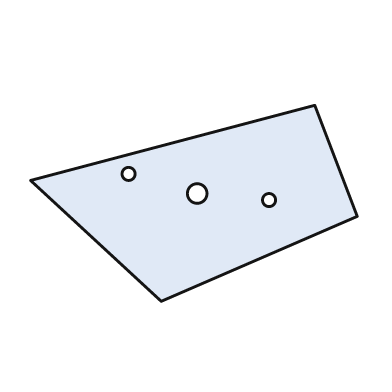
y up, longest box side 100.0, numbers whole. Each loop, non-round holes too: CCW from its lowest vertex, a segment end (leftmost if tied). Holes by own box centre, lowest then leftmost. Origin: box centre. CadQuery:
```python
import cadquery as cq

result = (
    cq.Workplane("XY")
    .moveTo(-10.0, -30.0)
    .lineTo(50.0, -4.0)
    .lineTo(37.0, 30.0)
    .lineTo(-50.0, 7.0)
    .close()
    .moveTo(23.0, 1.0)
    .circle(2.0)
    .moveTo(1.0, 3.0)
    .circle(3.0)
    .moveTo(-20.0, 9.0)
    .circle(2.0)
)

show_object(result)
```